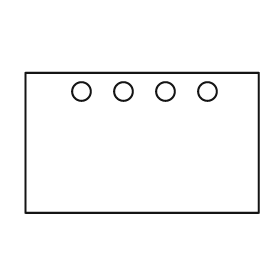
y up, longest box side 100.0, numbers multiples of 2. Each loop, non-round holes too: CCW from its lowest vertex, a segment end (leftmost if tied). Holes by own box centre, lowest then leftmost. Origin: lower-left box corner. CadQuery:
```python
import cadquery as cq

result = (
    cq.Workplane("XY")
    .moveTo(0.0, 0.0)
    .lineTo(100.0, 0.0)
    .lineTo(100.0, 60.0)
    .lineTo(0.0, 60.0)
    .close()
    .moveTo(24.0, 52.0)
    .circle(4.0)
    .moveTo(42.0, 52.0)
    .circle(4.0)
    .moveTo(60.0, 52.0)
    .circle(4.0)
    .moveTo(78.0, 52.0)
    .circle(4.0)
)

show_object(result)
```